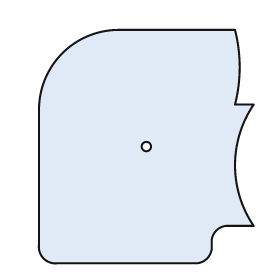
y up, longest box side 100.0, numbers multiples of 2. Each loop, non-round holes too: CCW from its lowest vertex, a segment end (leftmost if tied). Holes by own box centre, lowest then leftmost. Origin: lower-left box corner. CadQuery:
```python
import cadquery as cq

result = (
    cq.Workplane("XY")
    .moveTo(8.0, 0.0)
    .lineTo(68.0, 0.0)
    .threePointArc((72.0, 2.0), (74.0, 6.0))
    .lineTo(74.0, 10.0)
    .threePointArc((76.0, 14.0), (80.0, 16.0))
    .lineTo(92.0, 16.0)
    .threePointArc((84.0, 42.0), (92.0, 68.0))
    .lineTo(84.0, 68.0)
    .threePointArc((86.0, 84.0), (84.0, 100.0))
    .lineTo(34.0, 100.0)
    .threePointArc((10.0, 90.0), (0.0, 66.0))
    .lineTo(0.0, 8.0)
    .threePointArc((2.0, 2.0), (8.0, 0.0))
    .close()
    .moveTo(46.0, 50.0)
    .circle(2.0)
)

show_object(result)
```